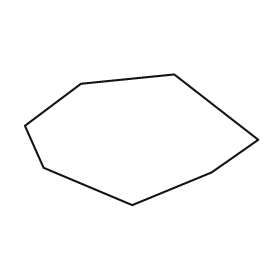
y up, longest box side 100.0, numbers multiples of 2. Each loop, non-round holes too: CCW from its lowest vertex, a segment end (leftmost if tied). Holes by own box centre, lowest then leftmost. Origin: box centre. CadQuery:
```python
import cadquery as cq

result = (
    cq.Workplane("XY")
    .moveTo(-4.0, -28.0)
    .lineTo(30.0, -14.0)
    .lineTo(50.0, 0.0)
    .lineTo(14.0, 28.0)
    .lineTo(-26.0, 24.0)
    .lineTo(-50.0, 6.0)
    .lineTo(-42.0, -12.0)
    .close()
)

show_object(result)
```